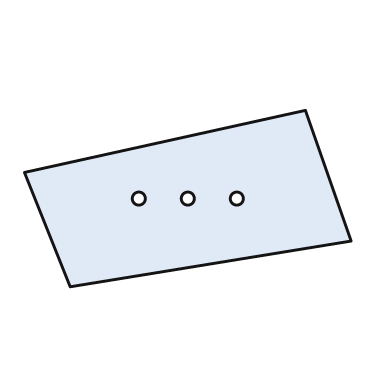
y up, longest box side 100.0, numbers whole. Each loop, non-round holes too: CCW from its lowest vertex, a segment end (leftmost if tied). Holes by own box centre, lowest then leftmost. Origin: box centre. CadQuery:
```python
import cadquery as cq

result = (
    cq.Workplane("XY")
    .moveTo(-36.0, -27.0)
    .lineTo(50.0, -13.0)
    .lineTo(36.0, 27.0)
    .lineTo(-50.0, 8.0)
    .close()
    .moveTo(-15.0, 0.0)
    .circle(2.0)
    .moveTo(0.0, 0.0)
    .circle(2.0)
    .moveTo(15.0, 0.0)
    .circle(2.0)
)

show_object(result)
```